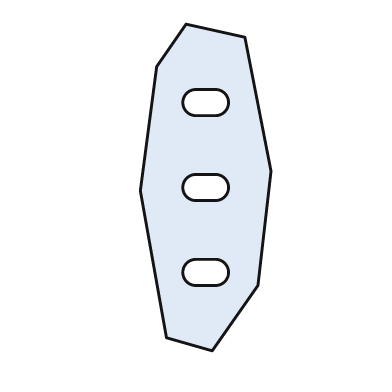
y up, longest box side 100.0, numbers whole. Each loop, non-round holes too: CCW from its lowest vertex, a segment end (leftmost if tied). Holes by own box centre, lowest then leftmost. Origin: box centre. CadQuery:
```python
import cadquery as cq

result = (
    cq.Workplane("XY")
    .moveTo(2.0, -50.0)
    .lineTo(16.0, -30.0)
    .lineTo(20.0, 5.0)
    .lineTo(12.0, 46.0)
    .lineTo(-6.0, 50.0)
    .lineTo(-15.0, 37.0)
    .lineTo(-20.0, -1.0)
    .lineTo(-12.0, -46.0)
    .close()
    .moveTo(-3.0, -30.0)
    .lineTo(3.0, -30.0)
    .threePointArc((7.0, -26.0), (3.0, -22.0))
    .lineTo(-3.0, -22.0)
    .threePointArc((-7.0, -26.0), (-3.0, -30.0))
    .close()
    .moveTo(-3.0, -4.0)
    .lineTo(3.0, -4.0)
    .threePointArc((7.0, 0.0), (3.0, 4.0))
    .lineTo(-3.0, 4.0)
    .threePointArc((-7.0, 0.0), (-3.0, -4.0))
    .close()
    .moveTo(-3.0, 22.0)
    .lineTo(3.0, 22.0)
    .threePointArc((7.0, 26.0), (3.0, 30.0))
    .lineTo(-3.0, 30.0)
    .threePointArc((-7.0, 26.0), (-3.0, 22.0))
    .close()
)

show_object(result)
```